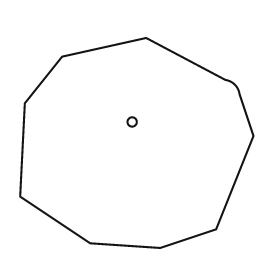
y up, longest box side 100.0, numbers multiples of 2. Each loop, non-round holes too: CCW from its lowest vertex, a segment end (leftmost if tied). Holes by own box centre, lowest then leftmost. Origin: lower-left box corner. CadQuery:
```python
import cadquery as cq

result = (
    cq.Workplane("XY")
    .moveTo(60.0, 0.0)
    .lineTo(84.0, 8.0)
    .lineTo(100.0, 48.0)
    .lineTo(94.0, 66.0)
    .threePointArc((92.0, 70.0), (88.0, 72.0))
    .lineTo(54.0, 90.0)
    .lineTo(18.0, 82.0)
    .lineTo(2.0, 62.0)
    .lineTo(0.0, 22.0)
    .lineTo(30.0, 2.0)
    .close()
    .moveTo(48.0, 54.0)
    .circle(2.0)
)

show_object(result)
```